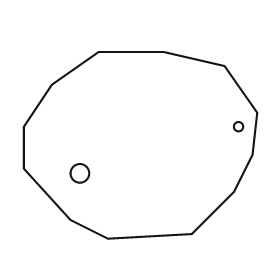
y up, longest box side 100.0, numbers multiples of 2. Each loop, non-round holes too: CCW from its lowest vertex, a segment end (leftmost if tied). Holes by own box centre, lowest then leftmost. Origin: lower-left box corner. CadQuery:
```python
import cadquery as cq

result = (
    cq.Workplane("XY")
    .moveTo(36.0, 0.0)
    .lineTo(72.0, 2.0)
    .lineTo(90.0, 20.0)
    .lineTo(98.0, 36.0)
    .lineTo(100.0, 54.0)
    .lineTo(86.0, 74.0)
    .lineTo(60.0, 80.0)
    .lineTo(32.0, 80.0)
    .lineTo(12.0, 66.0)
    .lineTo(0.0, 48.0)
    .lineTo(0.0, 30.0)
    .lineTo(20.0, 8.0)
    .close()
    .moveTo(24.0, 28.0)
    .circle(4.0)
    .moveTo(92.0, 48.0)
    .circle(2.0)
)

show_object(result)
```